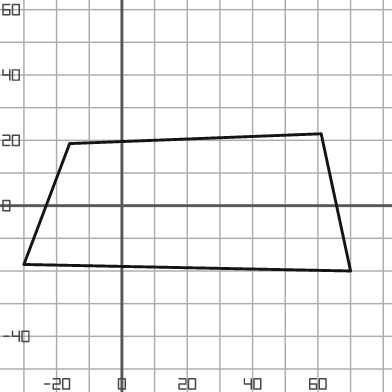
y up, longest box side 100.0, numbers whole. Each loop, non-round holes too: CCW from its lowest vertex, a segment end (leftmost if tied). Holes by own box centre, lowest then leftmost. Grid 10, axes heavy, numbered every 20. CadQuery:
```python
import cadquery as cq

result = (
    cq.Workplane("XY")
    .moveTo(70.0, -20.0)
    .lineTo(61.0, 22.0)
    .lineTo(-16.0, 19.0)
    .lineTo(-30.0, -18.0)
    .close()
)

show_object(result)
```